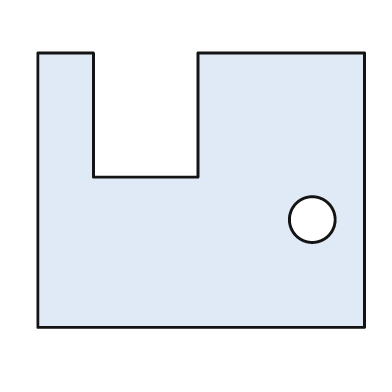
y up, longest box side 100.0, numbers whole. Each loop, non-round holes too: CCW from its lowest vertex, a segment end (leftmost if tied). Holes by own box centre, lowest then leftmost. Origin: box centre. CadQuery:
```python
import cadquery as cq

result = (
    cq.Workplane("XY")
    .moveTo(-50.0, -42.0)
    .lineTo(50.0, -42.0)
    .lineTo(50.0, 42.0)
    .lineTo(-1.0, 42.0)
    .lineTo(-1.0, 4.0)
    .lineTo(-33.0, 4.0)
    .lineTo(-33.0, 42.0)
    .lineTo(-50.0, 42.0)
    .close()
    .moveTo(34.0, -9.0)
    .circle(7.0)
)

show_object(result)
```